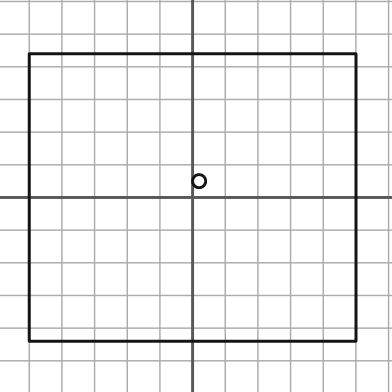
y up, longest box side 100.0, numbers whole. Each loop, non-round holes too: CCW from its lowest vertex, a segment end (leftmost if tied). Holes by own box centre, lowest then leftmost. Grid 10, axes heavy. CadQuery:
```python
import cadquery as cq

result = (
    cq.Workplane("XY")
    .moveTo(-50.0, -44.0)
    .lineTo(50.0, -44.0)
    .lineTo(50.0, 44.0)
    .lineTo(-50.0, 44.0)
    .close()
    .moveTo(2.0, 5.0)
    .circle(2.0)
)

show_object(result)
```